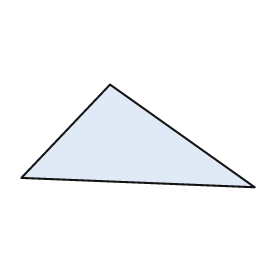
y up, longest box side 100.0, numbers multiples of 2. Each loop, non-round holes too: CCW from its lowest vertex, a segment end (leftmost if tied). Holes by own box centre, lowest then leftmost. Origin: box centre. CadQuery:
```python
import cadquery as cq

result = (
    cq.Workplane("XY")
    .moveTo(50.0, -22.0)
    .lineTo(-12.0, 22.0)
    .lineTo(-50.0, -18.0)
    .close()
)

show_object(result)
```